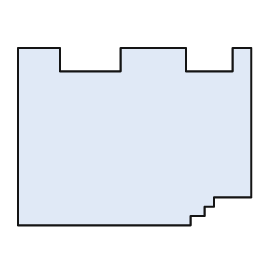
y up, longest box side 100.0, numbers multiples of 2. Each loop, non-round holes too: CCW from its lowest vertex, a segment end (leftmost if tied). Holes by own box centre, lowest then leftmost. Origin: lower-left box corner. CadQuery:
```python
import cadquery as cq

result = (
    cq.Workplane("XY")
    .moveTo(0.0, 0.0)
    .lineTo(74.0, 0.0)
    .lineTo(74.0, 4.0)
    .lineTo(80.0, 4.0)
    .lineTo(80.0, 8.0)
    .lineTo(84.0, 8.0)
    .lineTo(84.0, 12.0)
    .lineTo(100.0, 12.0)
    .lineTo(100.0, 76.0)
    .lineTo(92.0, 76.0)
    .lineTo(92.0, 66.0)
    .lineTo(72.0, 66.0)
    .lineTo(72.0, 76.0)
    .lineTo(44.0, 76.0)
    .lineTo(44.0, 66.0)
    .lineTo(18.0, 66.0)
    .lineTo(18.0, 76.0)
    .lineTo(0.0, 76.0)
    .close()
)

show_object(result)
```